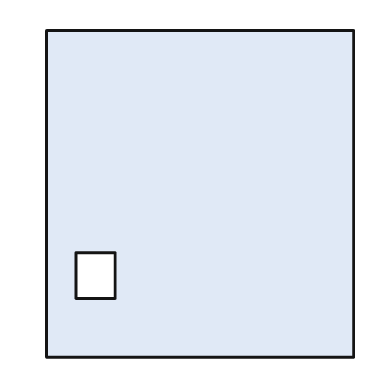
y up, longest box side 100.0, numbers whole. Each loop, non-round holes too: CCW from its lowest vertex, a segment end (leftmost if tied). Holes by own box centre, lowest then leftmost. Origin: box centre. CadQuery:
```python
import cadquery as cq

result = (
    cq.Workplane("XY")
    .moveTo(-47.0, -50.0)
    .lineTo(47.0, -50.0)
    .lineTo(47.0, 50.0)
    .lineTo(-47.0, 50.0)
    .close()
    .moveTo(-38.0, -32.0)
    .lineTo(-26.0, -32.0)
    .lineTo(-26.0, -18.0)
    .lineTo(-38.0, -18.0)
    .close()
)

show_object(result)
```